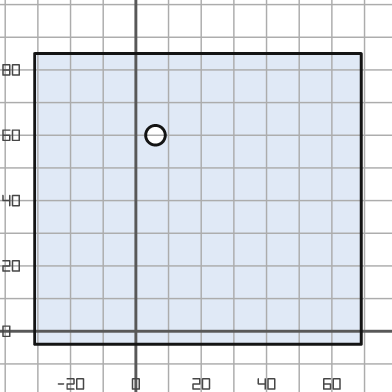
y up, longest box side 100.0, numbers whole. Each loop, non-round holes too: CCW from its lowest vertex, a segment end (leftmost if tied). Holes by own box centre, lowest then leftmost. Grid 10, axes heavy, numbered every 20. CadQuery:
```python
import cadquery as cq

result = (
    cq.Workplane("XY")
    .moveTo(-31.0, -4.0)
    .lineTo(69.0, -4.0)
    .lineTo(69.0, 85.0)
    .lineTo(-31.0, 85.0)
    .close()
    .moveTo(6.0, 60.0)
    .circle(3.0)
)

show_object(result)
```